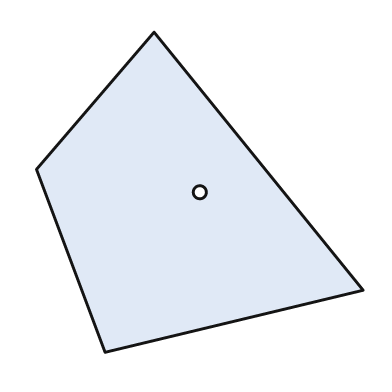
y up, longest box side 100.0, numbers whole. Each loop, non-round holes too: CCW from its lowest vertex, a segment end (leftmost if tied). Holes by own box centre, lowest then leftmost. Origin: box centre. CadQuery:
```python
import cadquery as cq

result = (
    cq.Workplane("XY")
    .moveTo(-29.0, -49.0)
    .lineTo(50.0, -30.0)
    .lineTo(-14.0, 49.0)
    .lineTo(-50.0, 7.0)
    .close()
    .moveTo(0.0, 0.0)
    .circle(2.0)
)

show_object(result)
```